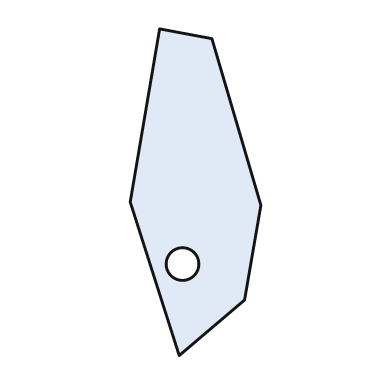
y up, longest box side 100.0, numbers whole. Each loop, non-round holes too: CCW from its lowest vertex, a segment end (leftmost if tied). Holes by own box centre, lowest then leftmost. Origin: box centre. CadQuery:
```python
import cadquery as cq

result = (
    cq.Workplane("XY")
    .moveTo(-5.0, -50.0)
    .lineTo(15.0, -33.0)
    .lineTo(20.0, -4.0)
    .lineTo(5.0, 47.0)
    .lineTo(-11.0, 50.0)
    .lineTo(-20.0, -3.0)
    .close()
    .moveTo(-4.0, -22.0)
    .circle(5.0)
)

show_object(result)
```